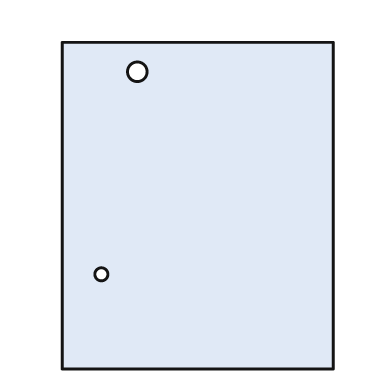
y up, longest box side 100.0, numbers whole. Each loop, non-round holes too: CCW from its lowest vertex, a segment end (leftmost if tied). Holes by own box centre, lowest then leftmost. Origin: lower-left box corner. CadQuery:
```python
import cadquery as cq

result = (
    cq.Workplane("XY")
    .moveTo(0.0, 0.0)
    .lineTo(83.0, 0.0)
    .lineTo(83.0, 100.0)
    .lineTo(0.0, 100.0)
    .close()
    .moveTo(12.0, 29.0)
    .circle(2.0)
    .moveTo(23.0, 91.0)
    .circle(3.0)
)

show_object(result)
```